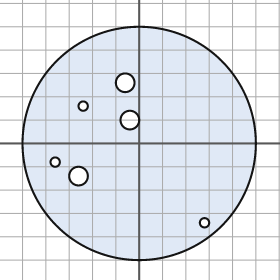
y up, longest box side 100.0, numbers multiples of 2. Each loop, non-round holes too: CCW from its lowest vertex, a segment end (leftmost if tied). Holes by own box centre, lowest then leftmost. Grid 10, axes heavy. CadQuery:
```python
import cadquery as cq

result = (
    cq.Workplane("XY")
    .moveTo(0.0, 0.0)
    .circle(50.0)
    .moveTo(28.0, -34.0)
    .circle(2.0)
    .moveTo(-26.0, -14.0)
    .circle(4.0)
    .moveTo(-36.0, -8.0)
    .circle(2.0)
    .moveTo(-4.0, 10.0)
    .circle(4.0)
    .moveTo(-24.0, 16.0)
    .circle(2.0)
    .moveTo(-6.0, 26.0)
    .circle(4.0)
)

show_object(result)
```